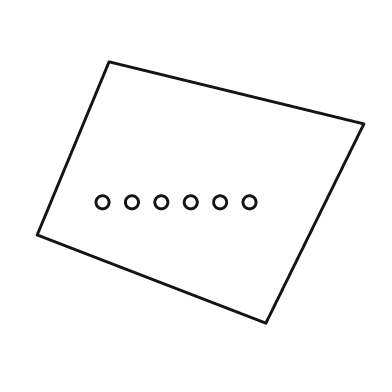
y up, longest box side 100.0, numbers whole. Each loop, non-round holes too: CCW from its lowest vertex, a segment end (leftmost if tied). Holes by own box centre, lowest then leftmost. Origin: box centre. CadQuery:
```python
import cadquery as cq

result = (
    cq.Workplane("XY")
    .moveTo(20.0, -40.0)
    .lineTo(50.0, 21.0)
    .lineTo(-28.0, 40.0)
    .lineTo(-50.0, -13.0)
    .close()
    .moveTo(-30.0, -3.0)
    .circle(2.0)
    .moveTo(-21.0, -3.0)
    .circle(2.0)
    .moveTo(-12.0, -3.0)
    .circle(2.0)
    .moveTo(-3.0, -3.0)
    .circle(2.0)
    .moveTo(6.0, -3.0)
    .circle(2.0)
    .moveTo(15.0, -3.0)
    .circle(2.0)
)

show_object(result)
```